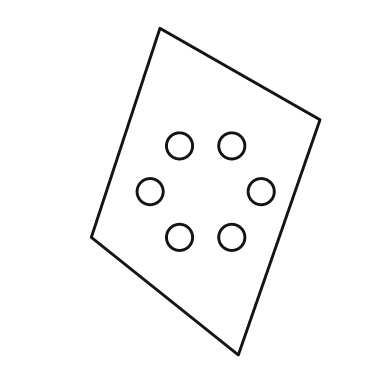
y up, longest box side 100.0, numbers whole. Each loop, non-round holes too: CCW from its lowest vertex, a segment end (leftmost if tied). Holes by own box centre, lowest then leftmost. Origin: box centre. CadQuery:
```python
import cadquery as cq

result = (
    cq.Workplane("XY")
    .moveTo(10.0, -50.0)
    .lineTo(35.0, 22.0)
    .lineTo(-14.0, 50.0)
    .lineTo(-35.0, -14.0)
    .close()
    .moveTo(-8.0, -14.0)
    .circle(4.0)
    .moveTo(8.0, -14.0)
    .circle(4.0)
    .moveTo(-17.0, 0.0)
    .circle(4.0)
    .moveTo(17.0, 0.0)
    .circle(4.0)
    .moveTo(-8.0, 14.0)
    .circle(4.0)
    .moveTo(8.0, 14.0)
    .circle(4.0)
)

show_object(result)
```